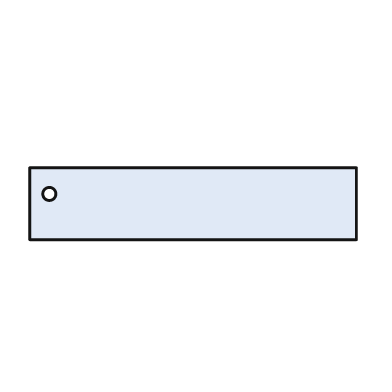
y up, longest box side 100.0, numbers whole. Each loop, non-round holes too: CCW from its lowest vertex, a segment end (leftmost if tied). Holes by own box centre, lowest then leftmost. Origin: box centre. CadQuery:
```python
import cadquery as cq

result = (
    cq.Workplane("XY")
    .moveTo(-50.0, -11.0)
    .lineTo(50.0, -11.0)
    .lineTo(50.0, 11.0)
    .lineTo(-50.0, 11.0)
    .close()
    .moveTo(-44.0, 3.0)
    .circle(2.0)
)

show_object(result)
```